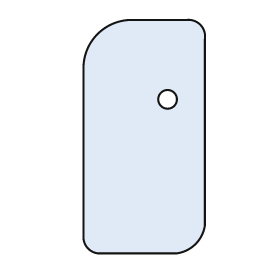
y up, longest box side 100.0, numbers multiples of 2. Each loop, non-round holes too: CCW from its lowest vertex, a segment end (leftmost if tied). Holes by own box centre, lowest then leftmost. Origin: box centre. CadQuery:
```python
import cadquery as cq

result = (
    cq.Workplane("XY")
    .moveTo(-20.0, -50.0)
    .lineTo(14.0, -50.0)
    .threePointArc((22.0, -46.0), (26.0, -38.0))
    .lineTo(26.0, 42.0)
    .threePointArc((24.0, 48.0), (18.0, 50.0))
    .lineTo(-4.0, 50.0)
    .threePointArc((-20.0, 44.0), (-26.0, 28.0))
    .lineTo(-26.0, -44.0)
    .threePointArc((-24.0, -48.0), (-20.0, -50.0))
    .close()
    .moveTo(10.0, 16.0)
    .circle(4.0)
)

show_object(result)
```